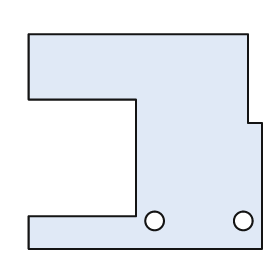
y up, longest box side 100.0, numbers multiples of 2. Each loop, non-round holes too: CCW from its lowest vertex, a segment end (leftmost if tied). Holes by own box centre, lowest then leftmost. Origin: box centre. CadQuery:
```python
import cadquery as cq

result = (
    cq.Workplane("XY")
    .moveTo(-50.0, -46.0)
    .lineTo(50.0, -46.0)
    .lineTo(50.0, 8.0)
    .lineTo(44.0, 8.0)
    .lineTo(44.0, 46.0)
    .lineTo(-50.0, 46.0)
    .lineTo(-50.0, 18.0)
    .lineTo(-4.0, 18.0)
    .lineTo(-4.0, -32.0)
    .lineTo(-50.0, -32.0)
    .close()
    .moveTo(4.0, -34.0)
    .circle(4.0)
    .moveTo(42.0, -34.0)
    .circle(4.0)
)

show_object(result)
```